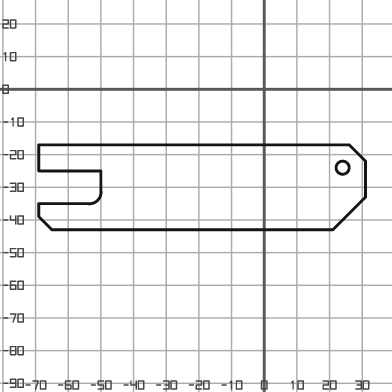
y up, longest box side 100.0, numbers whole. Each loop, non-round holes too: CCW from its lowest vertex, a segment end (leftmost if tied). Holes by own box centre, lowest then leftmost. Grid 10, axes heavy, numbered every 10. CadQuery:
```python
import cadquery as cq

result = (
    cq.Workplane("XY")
    .moveTo(-65.0, -43.0)
    .lineTo(21.0, -43.0)
    .lineTo(31.0, -33.0)
    .lineTo(31.0, -22.0)
    .lineTo(26.0, -17.0)
    .lineTo(-69.0, -17.0)
    .lineTo(-69.0, -25.0)
    .lineTo(-50.0, -25.0)
    .lineTo(-50.0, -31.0)
    .threePointArc((-51.0, -34.0), (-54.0, -35.0))
    .lineTo(-69.0, -35.0)
    .lineTo(-69.0, -39.0)
    .close()
    .moveTo(24.0, -24.0)
    .circle(2.0)
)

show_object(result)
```